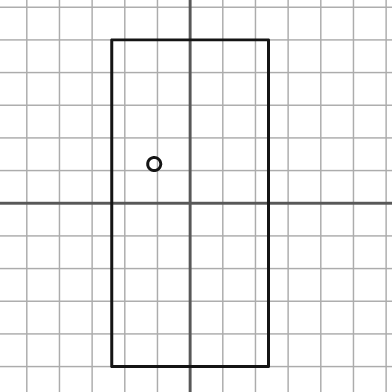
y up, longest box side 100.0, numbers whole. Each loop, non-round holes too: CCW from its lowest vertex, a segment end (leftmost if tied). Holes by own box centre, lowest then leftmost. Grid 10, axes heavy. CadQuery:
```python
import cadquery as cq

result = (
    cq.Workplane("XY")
    .moveTo(-24.0, -50.0)
    .lineTo(24.0, -50.0)
    .lineTo(24.0, 50.0)
    .lineTo(-24.0, 50.0)
    .close()
    .moveTo(-11.0, 12.0)
    .circle(2.0)
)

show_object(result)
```